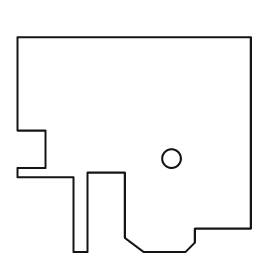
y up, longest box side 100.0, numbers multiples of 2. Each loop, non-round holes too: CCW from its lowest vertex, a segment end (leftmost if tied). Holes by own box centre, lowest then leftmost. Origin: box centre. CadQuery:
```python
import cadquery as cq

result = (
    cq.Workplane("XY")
    .moveTo(-26.0, -46.0)
    .lineTo(-20.0, -46.0)
    .lineTo(-20.0, -12.0)
    .lineTo(-4.0, -12.0)
    .lineTo(-4.0, -40.0)
    .lineTo(4.0, -46.0)
    .lineTo(22.0, -46.0)
    .lineTo(26.0, -42.0)
    .lineTo(26.0, -36.0)
    .lineTo(50.0, -36.0)
    .lineTo(50.0, 46.0)
    .lineTo(-50.0, 46.0)
    .lineTo(-50.0, 6.0)
    .lineTo(-38.0, 6.0)
    .lineTo(-38.0, -10.0)
    .lineTo(-50.0, -10.0)
    .lineTo(-50.0, -14.0)
    .lineTo(-26.0, -14.0)
    .close()
    .moveTo(16.0, -6.0)
    .circle(4.0)
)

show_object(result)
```